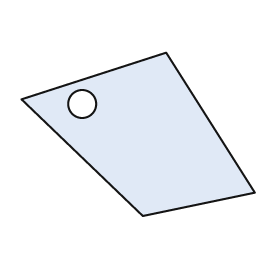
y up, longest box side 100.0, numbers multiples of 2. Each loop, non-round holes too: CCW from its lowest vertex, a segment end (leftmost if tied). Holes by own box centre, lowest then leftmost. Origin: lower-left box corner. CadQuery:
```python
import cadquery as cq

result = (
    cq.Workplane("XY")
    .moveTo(52.0, 0.0)
    .lineTo(100.0, 10.0)
    .lineTo(62.0, 70.0)
    .lineTo(0.0, 50.0)
    .close()
    .moveTo(26.0, 48.0)
    .circle(6.0)
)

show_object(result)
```